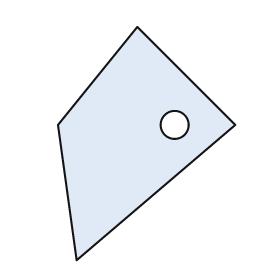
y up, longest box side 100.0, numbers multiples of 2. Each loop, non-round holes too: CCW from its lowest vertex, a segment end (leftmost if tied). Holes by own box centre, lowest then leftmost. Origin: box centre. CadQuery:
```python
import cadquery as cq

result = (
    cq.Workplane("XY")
    .moveTo(-30.0, -50.0)
    .lineTo(38.0, 8.0)
    .lineTo(-4.0, 50.0)
    .lineTo(-38.0, 8.0)
    .close()
    .moveTo(12.0, 8.0)
    .circle(6.0)
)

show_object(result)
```